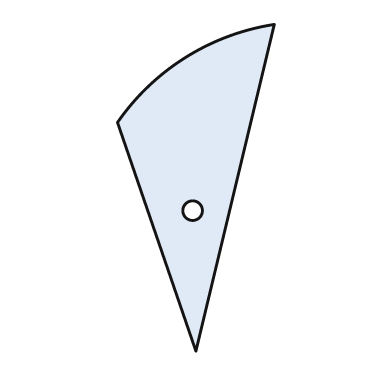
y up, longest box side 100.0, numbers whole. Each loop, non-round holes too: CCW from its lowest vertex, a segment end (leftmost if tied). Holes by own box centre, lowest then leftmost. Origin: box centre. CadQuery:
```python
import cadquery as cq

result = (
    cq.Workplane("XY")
    .moveTo(0.0, -50.0)
    .lineTo(24.0, 50.0)
    .threePointArc((-3.0, 40.0), (-24.0, 20.0))
    .close()
    .moveTo(-1.0, -7.0)
    .circle(3.0)
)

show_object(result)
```